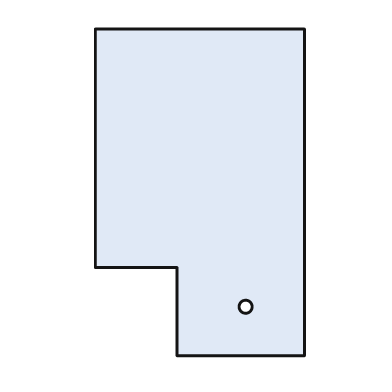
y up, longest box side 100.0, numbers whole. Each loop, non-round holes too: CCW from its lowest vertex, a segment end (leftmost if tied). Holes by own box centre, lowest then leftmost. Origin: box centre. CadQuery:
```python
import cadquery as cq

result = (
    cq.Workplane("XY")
    .moveTo(-7.0, -50.0)
    .lineTo(32.0, -50.0)
    .lineTo(32.0, 50.0)
    .lineTo(-32.0, 50.0)
    .lineTo(-32.0, -23.0)
    .lineTo(-7.0, -23.0)
    .close()
    .moveTo(14.0, -35.0)
    .circle(2.0)
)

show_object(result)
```